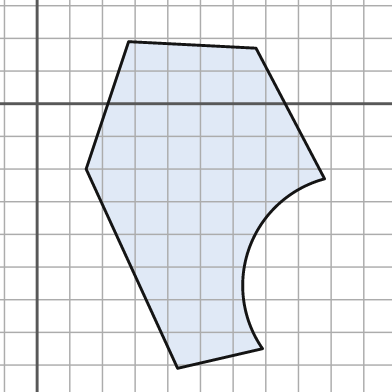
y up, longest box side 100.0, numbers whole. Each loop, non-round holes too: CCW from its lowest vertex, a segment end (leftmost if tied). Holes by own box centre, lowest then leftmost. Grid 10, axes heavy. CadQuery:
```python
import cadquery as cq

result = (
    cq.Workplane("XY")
    .moveTo(43.0, -81.0)
    .lineTo(69.0, -75.0)
    .threePointArc((65.0, -44.0), (88.0, -23.0))
    .lineTo(67.0, 17.0)
    .lineTo(28.0, 19.0)
    .lineTo(15.0, -20.0)
    .close()
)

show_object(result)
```